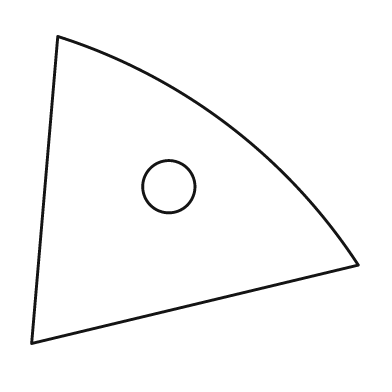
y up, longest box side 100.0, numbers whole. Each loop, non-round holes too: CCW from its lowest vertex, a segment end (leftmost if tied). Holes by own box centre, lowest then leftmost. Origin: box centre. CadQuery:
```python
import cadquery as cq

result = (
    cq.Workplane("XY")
    .moveTo(-50.0, -47.0)
    .lineTo(50.0, -23.0)
    .threePointArc((10.0, 20.0), (-42.0, 47.0))
    .close()
    .moveTo(-8.0, 1.0)
    .circle(8.0)
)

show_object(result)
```